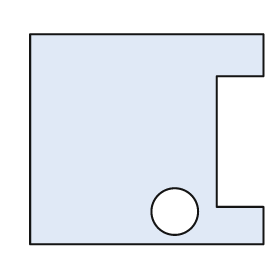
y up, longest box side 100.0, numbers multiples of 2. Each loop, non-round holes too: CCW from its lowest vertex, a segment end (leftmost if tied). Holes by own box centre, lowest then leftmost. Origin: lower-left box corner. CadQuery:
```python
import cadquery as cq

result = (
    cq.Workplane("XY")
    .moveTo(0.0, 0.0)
    .lineTo(100.0, 0.0)
    .lineTo(100.0, 16.0)
    .lineTo(80.0, 16.0)
    .lineTo(80.0, 72.0)
    .lineTo(100.0, 72.0)
    .lineTo(100.0, 90.0)
    .lineTo(0.0, 90.0)
    .close()
    .moveTo(62.0, 14.0)
    .circle(10.0)
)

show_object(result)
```